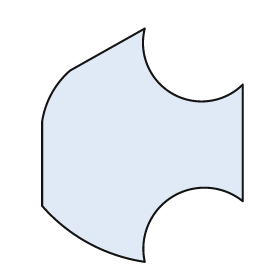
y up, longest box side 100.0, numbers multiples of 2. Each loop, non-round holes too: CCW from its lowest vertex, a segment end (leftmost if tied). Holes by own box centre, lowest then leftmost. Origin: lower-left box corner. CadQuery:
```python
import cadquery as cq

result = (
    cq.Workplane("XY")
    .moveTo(44.0, 0.0)
    .threePointArc((56.0, 28.0), (86.0, 26.0))
    .lineTo(86.0, 76.0)
    .threePointArc((56.0, 72.0), (44.0, 100.0))
    .lineTo(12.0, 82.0)
    .threePointArc((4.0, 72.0), (0.0, 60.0))
    .lineTo(0.0, 24.0)
    .threePointArc((20.0, 8.0), (44.0, 0.0))
    .close()
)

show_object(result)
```